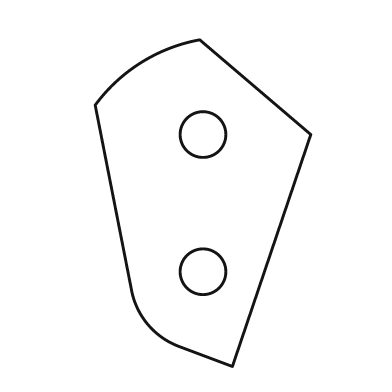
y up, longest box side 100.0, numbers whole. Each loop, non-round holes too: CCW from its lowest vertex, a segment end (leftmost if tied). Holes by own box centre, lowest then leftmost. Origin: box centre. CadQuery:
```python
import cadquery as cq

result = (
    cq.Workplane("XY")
    .moveTo(9.0, -50.0)
    .lineTo(33.0, 21.0)
    .lineTo(-1.0, 50.0)
    .threePointArc((-19.0, 43.0), (-33.0, 30.0))
    .lineTo(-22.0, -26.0)
    .threePointArc((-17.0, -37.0), (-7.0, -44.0))
    .close()
    .moveTo(0.0, -21.0)
    .circle(7.0)
    .moveTo(0.0, 21.0)
    .circle(7.0)
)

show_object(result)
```